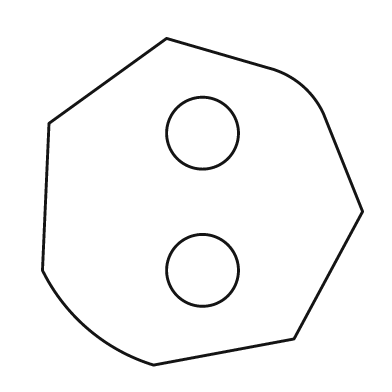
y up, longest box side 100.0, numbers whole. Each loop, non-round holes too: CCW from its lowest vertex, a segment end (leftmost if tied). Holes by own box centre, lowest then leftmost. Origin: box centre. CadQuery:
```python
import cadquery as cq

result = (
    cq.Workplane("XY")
    .moveTo(-15.0, -50.0)
    .lineTo(28.0, -42.0)
    .lineTo(49.0, -3.0)
    .lineTo(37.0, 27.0)
    .threePointArc((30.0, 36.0), (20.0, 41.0))
    .lineTo(-11.0, 50.0)
    .lineTo(-47.0, 24.0)
    .lineTo(-49.0, -21.0)
    .threePointArc((-35.0, -39.0), (-15.0, -50.0))
    .close()
    .moveTo(0.0, -21.0)
    .circle(11.0)
    .moveTo(0.0, 21.0)
    .circle(11.0)
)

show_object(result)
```